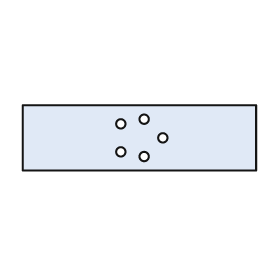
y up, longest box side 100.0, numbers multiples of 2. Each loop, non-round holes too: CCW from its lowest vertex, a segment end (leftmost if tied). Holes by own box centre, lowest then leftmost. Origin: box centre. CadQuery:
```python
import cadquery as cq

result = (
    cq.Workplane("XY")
    .moveTo(-50.0, -14.0)
    .lineTo(50.0, -14.0)
    .lineTo(50.0, 14.0)
    .lineTo(-50.0, 14.0)
    .close()
    .moveTo(2.0, -8.0)
    .circle(2.0)
    .moveTo(-8.0, -6.0)
    .circle(2.0)
    .moveTo(10.0, 0.0)
    .circle(2.0)
    .moveTo(-8.0, 6.0)
    .circle(2.0)
    .moveTo(2.0, 8.0)
    .circle(2.0)
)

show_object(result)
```